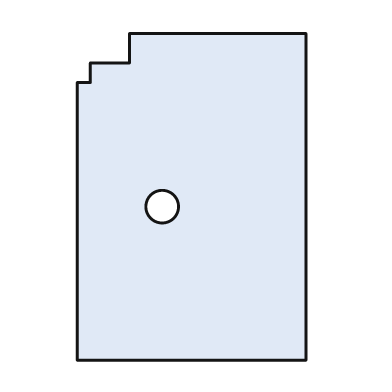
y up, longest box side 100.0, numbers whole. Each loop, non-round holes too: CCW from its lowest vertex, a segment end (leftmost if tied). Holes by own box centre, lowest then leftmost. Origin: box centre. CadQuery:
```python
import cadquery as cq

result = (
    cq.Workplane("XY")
    .moveTo(-35.0, -50.0)
    .lineTo(35.0, -50.0)
    .lineTo(35.0, 50.0)
    .lineTo(-19.0, 50.0)
    .lineTo(-19.0, 41.0)
    .lineTo(-31.0, 41.0)
    .lineTo(-31.0, 35.0)
    .lineTo(-35.0, 35.0)
    .close()
    .moveTo(-9.0, -3.0)
    .circle(5.0)
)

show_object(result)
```